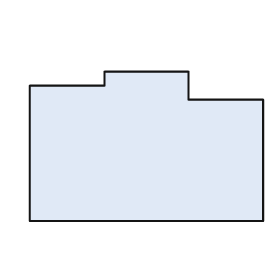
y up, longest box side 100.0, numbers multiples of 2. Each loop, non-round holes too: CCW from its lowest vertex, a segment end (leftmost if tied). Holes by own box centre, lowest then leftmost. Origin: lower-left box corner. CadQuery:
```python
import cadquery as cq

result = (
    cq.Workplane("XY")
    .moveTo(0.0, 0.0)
    .lineTo(100.0, 0.0)
    .lineTo(100.0, 52.0)
    .lineTo(68.0, 52.0)
    .lineTo(68.0, 64.0)
    .lineTo(32.0, 64.0)
    .lineTo(32.0, 58.0)
    .lineTo(0.0, 58.0)
    .close()
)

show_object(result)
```